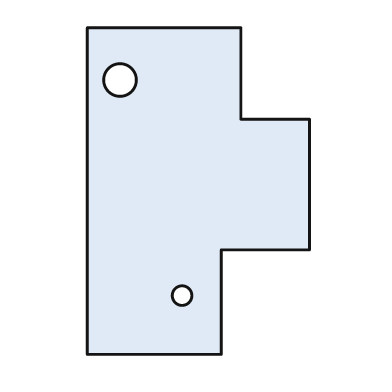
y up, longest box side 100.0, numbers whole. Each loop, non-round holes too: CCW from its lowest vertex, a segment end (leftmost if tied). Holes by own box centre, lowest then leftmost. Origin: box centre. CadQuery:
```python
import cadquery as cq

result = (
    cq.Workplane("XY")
    .moveTo(-34.0, -50.0)
    .lineTo(7.0, -50.0)
    .lineTo(7.0, -18.0)
    .lineTo(34.0, -18.0)
    .lineTo(34.0, 22.0)
    .lineTo(13.0, 22.0)
    .lineTo(13.0, 50.0)
    .lineTo(-34.0, 50.0)
    .close()
    .moveTo(-5.0, -32.0)
    .circle(3.0)
    .moveTo(-24.0, 34.0)
    .circle(5.0)
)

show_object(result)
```